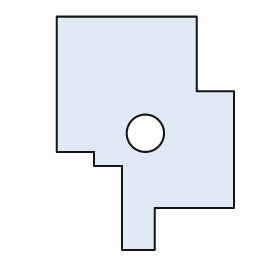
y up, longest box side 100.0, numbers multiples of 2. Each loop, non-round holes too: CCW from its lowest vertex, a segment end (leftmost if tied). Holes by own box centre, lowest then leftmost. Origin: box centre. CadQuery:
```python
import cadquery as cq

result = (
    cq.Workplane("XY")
    .moveTo(-10.0, -50.0)
    .lineTo(4.0, -50.0)
    .lineTo(4.0, -32.0)
    .lineTo(38.0, -32.0)
    .lineTo(38.0, 18.0)
    .lineTo(22.0, 18.0)
    .lineTo(22.0, 50.0)
    .lineTo(-38.0, 50.0)
    .lineTo(-38.0, -8.0)
    .lineTo(-22.0, -8.0)
    .lineTo(-22.0, -14.0)
    .lineTo(-10.0, -14.0)
    .close()
    .moveTo(0.0, 0.0)
    .circle(8.0)
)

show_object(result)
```